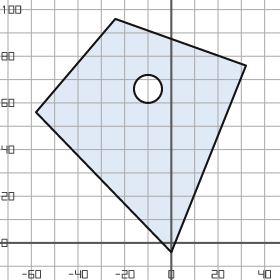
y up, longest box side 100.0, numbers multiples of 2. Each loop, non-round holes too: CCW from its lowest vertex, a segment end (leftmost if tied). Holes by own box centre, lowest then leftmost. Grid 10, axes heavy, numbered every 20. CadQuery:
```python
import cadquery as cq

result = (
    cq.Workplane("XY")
    .moveTo(0.0, -4.0)
    .lineTo(32.0, 76.0)
    .lineTo(-24.0, 96.0)
    .lineTo(-58.0, 56.0)
    .close()
    .moveTo(-10.0, 66.0)
    .circle(6.0)
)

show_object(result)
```